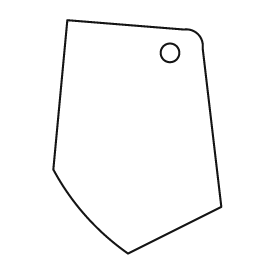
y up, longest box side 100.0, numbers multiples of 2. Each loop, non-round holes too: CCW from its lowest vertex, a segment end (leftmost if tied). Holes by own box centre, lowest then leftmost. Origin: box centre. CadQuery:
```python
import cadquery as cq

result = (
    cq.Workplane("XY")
    .moveTo(-4.0, -50.0)
    .lineTo(36.0, -30.0)
    .lineTo(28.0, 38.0)
    .threePointArc((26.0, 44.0), (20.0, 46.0))
    .lineTo(-30.0, 50.0)
    .lineTo(-36.0, -14.0)
    .threePointArc((-22.0, -34.0), (-4.0, -50.0))
    .close()
    .moveTo(14.0, 36.0)
    .circle(4.0)
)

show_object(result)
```